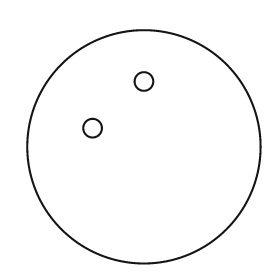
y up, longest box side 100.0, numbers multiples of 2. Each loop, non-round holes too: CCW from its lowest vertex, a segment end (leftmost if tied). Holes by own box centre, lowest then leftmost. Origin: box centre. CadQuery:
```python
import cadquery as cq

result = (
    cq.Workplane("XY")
    .moveTo(0.0, 0.0)
    .circle(50.0)
    .moveTo(-22.0, 8.0)
    .circle(4.0)
    .moveTo(0.0, 28.0)
    .circle(4.0)
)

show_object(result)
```